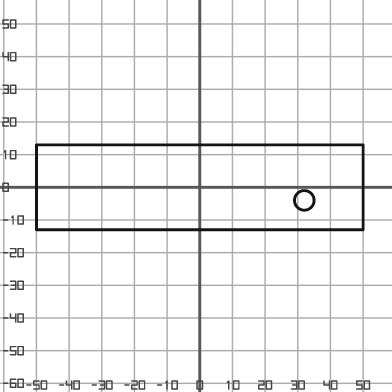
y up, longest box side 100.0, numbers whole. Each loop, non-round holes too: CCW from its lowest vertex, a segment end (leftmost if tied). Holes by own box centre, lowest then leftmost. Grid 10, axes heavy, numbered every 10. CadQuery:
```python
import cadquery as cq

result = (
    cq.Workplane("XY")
    .moveTo(-50.0, -13.0)
    .lineTo(50.0, -13.0)
    .lineTo(50.0, 13.0)
    .lineTo(-50.0, 13.0)
    .close()
    .moveTo(32.0, -4.0)
    .circle(3.0)
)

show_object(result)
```